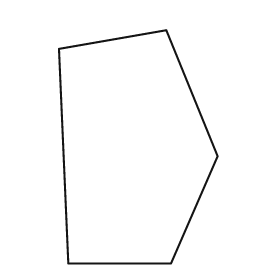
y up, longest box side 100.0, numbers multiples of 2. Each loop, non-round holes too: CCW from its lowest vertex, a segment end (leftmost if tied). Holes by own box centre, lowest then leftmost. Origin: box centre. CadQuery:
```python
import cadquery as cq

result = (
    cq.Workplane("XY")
    .moveTo(-30.0, -50.0)
    .lineTo(14.0, -50.0)
    .lineTo(34.0, -4.0)
    .lineTo(12.0, 50.0)
    .lineTo(-34.0, 42.0)
    .close()
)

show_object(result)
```